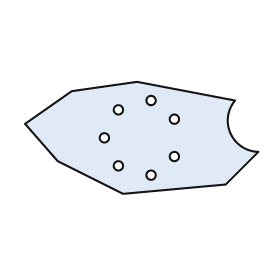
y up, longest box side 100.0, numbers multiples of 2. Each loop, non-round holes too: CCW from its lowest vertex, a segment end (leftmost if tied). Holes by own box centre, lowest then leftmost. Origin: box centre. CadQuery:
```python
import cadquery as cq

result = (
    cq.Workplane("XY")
    .moveTo(-8.0, -24.0)
    .lineTo(36.0, -20.0)
    .lineTo(50.0, -6.0)
    .threePointArc((38.0, 2.0), (40.0, 16.0))
    .lineTo(-2.0, 24.0)
    .lineTo(-30.0, 20.0)
    .lineTo(-50.0, 6.0)
    .lineTo(-36.0, -10.0)
    .close()
    .moveTo(4.0, -16.0)
    .circle(2.0)
    .moveTo(-10.0, -12.0)
    .circle(2.0)
    .moveTo(14.0, -8.0)
    .circle(2.0)
    .moveTo(-16.0, 0.0)
    .circle(2.0)
    .moveTo(14.0, 8.0)
    .circle(2.0)
    .moveTo(-10.0, 12.0)
    .circle(2.0)
    .moveTo(4.0, 16.0)
    .circle(2.0)
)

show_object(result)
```